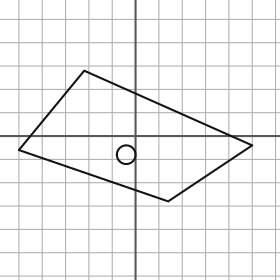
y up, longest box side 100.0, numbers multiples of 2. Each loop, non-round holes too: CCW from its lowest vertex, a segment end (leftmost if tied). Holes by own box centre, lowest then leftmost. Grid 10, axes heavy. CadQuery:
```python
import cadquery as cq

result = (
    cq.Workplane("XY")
    .moveTo(14.0, -28.0)
    .lineTo(50.0, -4.0)
    .lineTo(-22.0, 28.0)
    .lineTo(-50.0, -6.0)
    .close()
    .moveTo(-4.0, -8.0)
    .circle(4.0)
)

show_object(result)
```